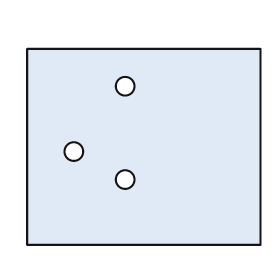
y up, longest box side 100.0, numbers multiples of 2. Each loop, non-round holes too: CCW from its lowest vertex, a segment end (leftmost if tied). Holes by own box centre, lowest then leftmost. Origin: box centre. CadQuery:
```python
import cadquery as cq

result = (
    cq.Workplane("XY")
    .moveTo(-50.0, -42.0)
    .lineTo(50.0, -42.0)
    .lineTo(50.0, 42.0)
    .lineTo(-50.0, 42.0)
    .close()
    .moveTo(-8.0, -14.0)
    .circle(4.0)
    .moveTo(-30.0, -2.0)
    .circle(4.0)
    .moveTo(-8.0, 26.0)
    .circle(4.0)
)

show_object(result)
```